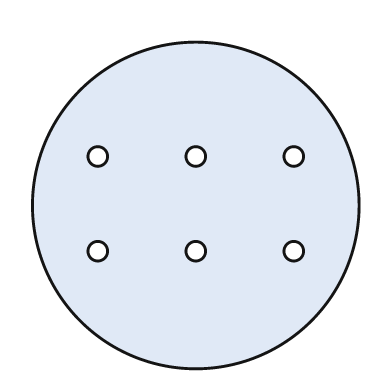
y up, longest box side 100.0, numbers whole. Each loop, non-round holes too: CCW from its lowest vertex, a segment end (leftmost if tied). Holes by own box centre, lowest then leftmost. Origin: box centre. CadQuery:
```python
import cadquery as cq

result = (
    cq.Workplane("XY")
    .moveTo(0.0, 0.0)
    .circle(50.0)
    .moveTo(-30.0, -14.0)
    .circle(3.0)
    .moveTo(0.0, -14.0)
    .circle(3.0)
    .moveTo(30.0, -14.0)
    .circle(3.0)
    .moveTo(-30.0, 15.0)
    .circle(3.0)
    .moveTo(0.0, 15.0)
    .circle(3.0)
    .moveTo(30.0, 15.0)
    .circle(3.0)
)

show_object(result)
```